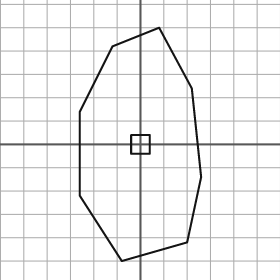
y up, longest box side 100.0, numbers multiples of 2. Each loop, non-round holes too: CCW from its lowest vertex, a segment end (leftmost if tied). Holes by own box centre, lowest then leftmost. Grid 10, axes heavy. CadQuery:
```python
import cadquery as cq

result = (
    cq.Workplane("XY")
    .moveTo(-8.0, -50.0)
    .lineTo(20.0, -42.0)
    .lineTo(26.0, -14.0)
    .lineTo(22.0, 24.0)
    .lineTo(8.0, 50.0)
    .lineTo(-12.0, 42.0)
    .lineTo(-26.0, 14.0)
    .lineTo(-26.0, -22.0)
    .close()
    .moveTo(-4.0, -4.0)
    .lineTo(4.0, -4.0)
    .lineTo(4.0, 4.0)
    .lineTo(-4.0, 4.0)
    .close()
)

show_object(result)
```